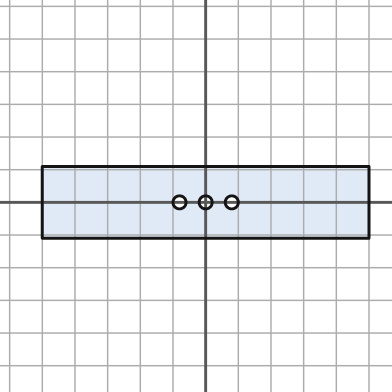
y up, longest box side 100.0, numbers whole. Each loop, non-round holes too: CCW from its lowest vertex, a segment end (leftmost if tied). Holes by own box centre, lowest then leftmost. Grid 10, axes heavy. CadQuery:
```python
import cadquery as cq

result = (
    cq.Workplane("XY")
    .moveTo(-50.0, -11.0)
    .lineTo(50.0, -11.0)
    .lineTo(50.0, 11.0)
    .lineTo(-50.0, 11.0)
    .close()
    .moveTo(-8.0, 0.0)
    .circle(2.0)
    .moveTo(0.0, 0.0)
    .circle(2.0)
    .moveTo(8.0, 0.0)
    .circle(2.0)
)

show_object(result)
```